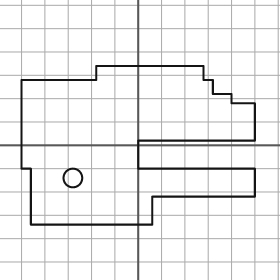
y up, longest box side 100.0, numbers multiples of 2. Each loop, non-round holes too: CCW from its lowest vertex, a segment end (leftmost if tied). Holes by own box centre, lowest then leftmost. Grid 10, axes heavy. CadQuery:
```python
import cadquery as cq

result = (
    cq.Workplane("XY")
    .moveTo(-46.0, -34.0)
    .lineTo(6.0, -34.0)
    .lineTo(6.0, -22.0)
    .lineTo(50.0, -22.0)
    .lineTo(50.0, -10.0)
    .lineTo(0.0, -10.0)
    .lineTo(0.0, 2.0)
    .lineTo(50.0, 2.0)
    .lineTo(50.0, 18.0)
    .lineTo(40.0, 18.0)
    .lineTo(40.0, 22.0)
    .lineTo(32.0, 22.0)
    .lineTo(32.0, 28.0)
    .lineTo(28.0, 28.0)
    .lineTo(28.0, 34.0)
    .lineTo(-18.0, 34.0)
    .lineTo(-18.0, 28.0)
    .lineTo(-50.0, 28.0)
    .lineTo(-50.0, -10.0)
    .lineTo(-46.0, -10.0)
    .close()
    .moveTo(-28.0, -14.0)
    .circle(4.0)
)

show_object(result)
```